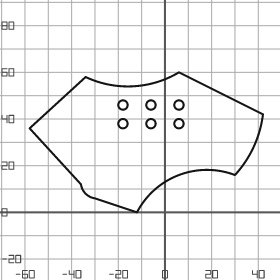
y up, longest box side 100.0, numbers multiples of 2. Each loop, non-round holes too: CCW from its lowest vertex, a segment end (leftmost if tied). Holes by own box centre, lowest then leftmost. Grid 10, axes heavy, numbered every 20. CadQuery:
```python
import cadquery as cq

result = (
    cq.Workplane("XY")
    .moveTo(-12.0, 0.0)
    .threePointArc((6.0, 16.0), (30.0, 16.0))
    .threePointArc((38.0, 28.0), (42.0, 42.0))
    .lineTo(6.0, 60.0)
    .threePointArc((-14.0, 54.0), (-34.0, 58.0))
    .lineTo(-58.0, 36.0)
    .lineTo(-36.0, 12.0)
    .threePointArc((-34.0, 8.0), (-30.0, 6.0))
    .close()
    .moveTo(-18.0, 38.0)
    .circle(2.0)
    .moveTo(-6.0, 38.0)
    .circle(2.0)
    .moveTo(6.0, 38.0)
    .circle(2.0)
    .moveTo(-18.0, 46.0)
    .circle(2.0)
    .moveTo(-6.0, 46.0)
    .circle(2.0)
    .moveTo(6.0, 46.0)
    .circle(2.0)
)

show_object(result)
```